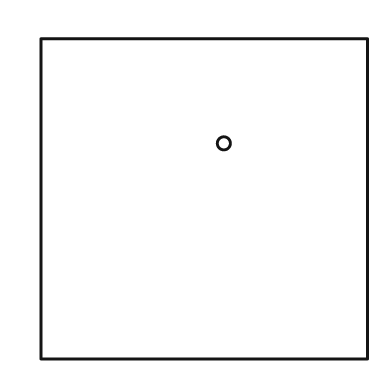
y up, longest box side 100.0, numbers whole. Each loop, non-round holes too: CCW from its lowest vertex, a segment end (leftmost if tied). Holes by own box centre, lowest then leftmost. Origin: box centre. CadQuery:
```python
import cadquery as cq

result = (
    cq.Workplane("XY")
    .moveTo(-50.0, -49.0)
    .lineTo(50.0, -49.0)
    .lineTo(50.0, 49.0)
    .lineTo(-50.0, 49.0)
    .close()
    .moveTo(6.0, 17.0)
    .circle(2.0)
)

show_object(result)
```